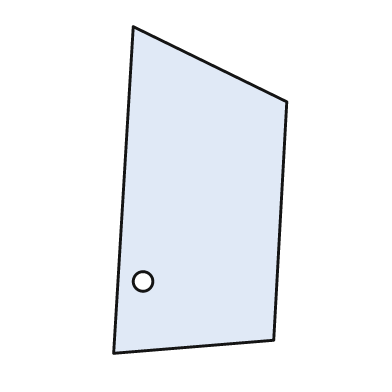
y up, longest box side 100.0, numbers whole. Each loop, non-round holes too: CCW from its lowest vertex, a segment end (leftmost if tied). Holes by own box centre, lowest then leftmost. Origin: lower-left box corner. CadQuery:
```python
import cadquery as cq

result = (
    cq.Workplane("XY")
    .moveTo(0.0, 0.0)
    .lineTo(49.0, 4.0)
    .lineTo(53.0, 77.0)
    .lineTo(6.0, 100.0)
    .close()
    .moveTo(9.0, 22.0)
    .circle(3.0)
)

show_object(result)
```